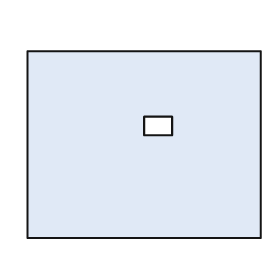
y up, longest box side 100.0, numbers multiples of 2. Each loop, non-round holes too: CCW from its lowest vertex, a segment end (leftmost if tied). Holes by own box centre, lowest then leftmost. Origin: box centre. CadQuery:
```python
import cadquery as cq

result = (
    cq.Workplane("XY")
    .moveTo(-50.0, -40.0)
    .lineTo(50.0, -40.0)
    .lineTo(50.0, 40.0)
    .lineTo(-50.0, 40.0)
    .close()
    .moveTo(0.0, 4.0)
    .lineTo(12.0, 4.0)
    .lineTo(12.0, 12.0)
    .lineTo(0.0, 12.0)
    .close()
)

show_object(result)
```